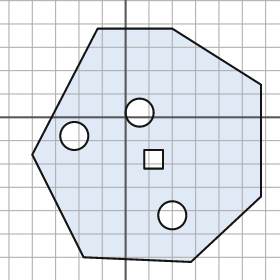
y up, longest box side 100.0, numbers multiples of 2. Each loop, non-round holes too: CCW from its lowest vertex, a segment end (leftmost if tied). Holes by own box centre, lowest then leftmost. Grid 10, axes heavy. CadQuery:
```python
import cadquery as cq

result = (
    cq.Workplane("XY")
    .moveTo(28.0, -62.0)
    .lineTo(58.0, -34.0)
    .lineTo(58.0, 14.0)
    .lineTo(20.0, 38.0)
    .lineTo(-12.0, 38.0)
    .lineTo(-40.0, -16.0)
    .lineTo(-18.0, -60.0)
    .close()
    .moveTo(20.0, -42.0)
    .circle(6.0)
    .moveTo(8.0, -22.0)
    .lineTo(16.0, -22.0)
    .lineTo(16.0, -14.0)
    .lineTo(8.0, -14.0)
    .close()
    .moveTo(-22.0, -8.0)
    .circle(6.0)
    .moveTo(6.0, 2.0)
    .circle(6.0)
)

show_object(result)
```